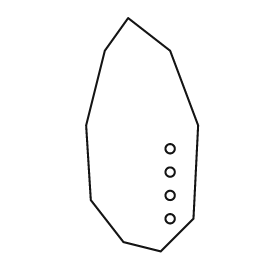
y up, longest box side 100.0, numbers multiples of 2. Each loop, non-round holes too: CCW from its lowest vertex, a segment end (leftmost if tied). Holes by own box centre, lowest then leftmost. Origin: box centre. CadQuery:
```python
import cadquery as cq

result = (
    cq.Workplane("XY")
    .moveTo(8.0, -50.0)
    .lineTo(22.0, -36.0)
    .lineTo(24.0, 4.0)
    .lineTo(12.0, 36.0)
    .lineTo(-6.0, 50.0)
    .lineTo(-16.0, 36.0)
    .lineTo(-24.0, 4.0)
    .lineTo(-22.0, -28.0)
    .lineTo(-8.0, -46.0)
    .close()
    .moveTo(12.0, -36.0)
    .circle(2.0)
    .moveTo(12.0, -26.0)
    .circle(2.0)
    .moveTo(12.0, -16.0)
    .circle(2.0)
    .moveTo(12.0, -6.0)
    .circle(2.0)
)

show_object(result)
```